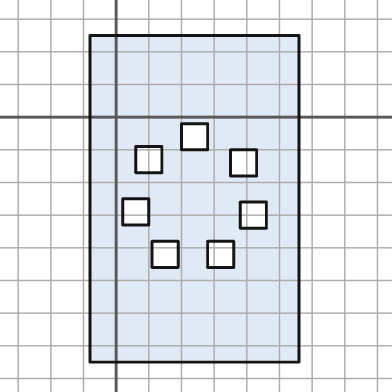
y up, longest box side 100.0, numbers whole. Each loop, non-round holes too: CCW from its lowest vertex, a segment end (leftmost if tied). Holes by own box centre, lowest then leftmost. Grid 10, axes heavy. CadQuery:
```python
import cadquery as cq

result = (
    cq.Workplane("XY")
    .moveTo(-8.0, -75.0)
    .lineTo(56.0, -75.0)
    .lineTo(56.0, 25.0)
    .lineTo(-8.0, 25.0)
    .close()
    .moveTo(11.0, -46.0)
    .lineTo(19.0, -46.0)
    .lineTo(19.0, -38.0)
    .lineTo(11.0, -38.0)
    .close()
    .moveTo(28.0, -46.0)
    .lineTo(36.0, -46.0)
    .lineTo(36.0, -38.0)
    .lineTo(28.0, -38.0)
    .close()
    .moveTo(38.0, -34.0)
    .lineTo(46.0, -34.0)
    .lineTo(46.0, -26.0)
    .lineTo(38.0, -26.0)
    .close()
    .moveTo(2.0, -33.0)
    .lineTo(10.0, -33.0)
    .lineTo(10.0, -25.0)
    .lineTo(2.0, -25.0)
    .close()
    .moveTo(35.0, -18.0)
    .lineTo(43.0, -18.0)
    .lineTo(43.0, -10.0)
    .lineTo(35.0, -10.0)
    .close()
    .moveTo(6.0, -17.0)
    .lineTo(14.0, -17.0)
    .lineTo(14.0, -9.0)
    .lineTo(6.0, -9.0)
    .close()
    .moveTo(20.0, -10.0)
    .lineTo(28.0, -10.0)
    .lineTo(28.0, -2.0)
    .lineTo(20.0, -2.0)
    .close()
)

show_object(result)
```